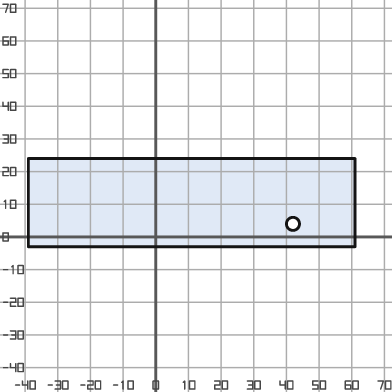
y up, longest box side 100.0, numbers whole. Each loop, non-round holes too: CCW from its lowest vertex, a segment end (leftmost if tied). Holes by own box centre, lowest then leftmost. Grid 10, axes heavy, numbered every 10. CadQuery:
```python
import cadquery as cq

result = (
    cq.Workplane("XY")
    .moveTo(-39.0, -3.0)
    .lineTo(61.0, -3.0)
    .lineTo(61.0, 24.0)
    .lineTo(-39.0, 24.0)
    .close()
    .moveTo(42.0, 4.0)
    .circle(2.0)
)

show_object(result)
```